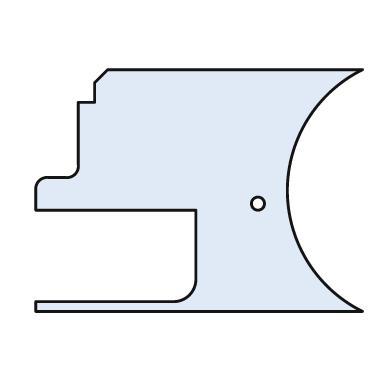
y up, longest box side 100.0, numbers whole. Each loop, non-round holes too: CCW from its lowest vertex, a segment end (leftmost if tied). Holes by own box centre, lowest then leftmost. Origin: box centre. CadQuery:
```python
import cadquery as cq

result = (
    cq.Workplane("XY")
    .moveTo(-50.0, -37.0)
    .lineTo(50.0, -37.0)
    .threePointArc((27.0, 0.0), (50.0, 37.0))
    .lineTo(-28.0, 37.0)
    .lineTo(-32.0, 33.0)
    .lineTo(-32.0, 27.0)
    .lineTo(-37.0, 27.0)
    .lineTo(-37.0, 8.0)
    .threePointArc((-38.0, 5.0), (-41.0, 4.0))
    .lineTo(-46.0, 4.0)
    .threePointArc((-49.0, 3.0), (-50.0, 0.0))
    .lineTo(-50.0, -6.0)
    .lineTo(-1.0, -6.0)
    .lineTo(-1.0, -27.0)
    .threePointArc((-3.0, -32.0), (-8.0, -34.0))
    .lineTo(-50.0, -34.0)
    .close()
    .moveTo(18.0, -4.0)
    .circle(2.0)
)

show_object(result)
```